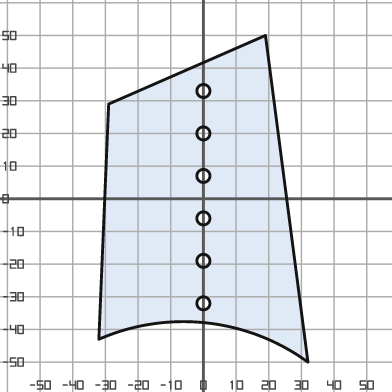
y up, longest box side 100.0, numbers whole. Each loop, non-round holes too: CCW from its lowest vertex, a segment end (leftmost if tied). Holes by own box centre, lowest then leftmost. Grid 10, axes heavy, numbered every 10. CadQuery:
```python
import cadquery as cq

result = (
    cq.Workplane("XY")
    .moveTo(32.0, -50.0)
    .lineTo(19.0, 50.0)
    .lineTo(-29.0, 29.0)
    .lineTo(-32.0, -43.0)
    .threePointArc((1.0, -38.0), (32.0, -50.0))
    .close()
    .moveTo(0.0, -32.0)
    .circle(2.0)
    .moveTo(0.0, -19.0)
    .circle(2.0)
    .moveTo(0.0, -6.0)
    .circle(2.0)
    .moveTo(0.0, 7.0)
    .circle(2.0)
    .moveTo(0.0, 20.0)
    .circle(2.0)
    .moveTo(0.0, 33.0)
    .circle(2.0)
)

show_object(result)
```